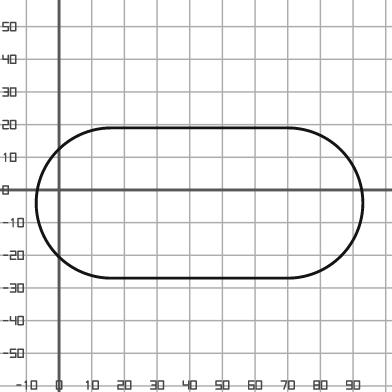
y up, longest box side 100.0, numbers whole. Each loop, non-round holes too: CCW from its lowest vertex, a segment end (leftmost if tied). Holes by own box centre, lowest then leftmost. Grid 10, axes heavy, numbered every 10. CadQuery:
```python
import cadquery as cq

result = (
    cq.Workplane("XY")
    .moveTo(16.0, -27.0)
    .lineTo(70.0, -27.0)
    .threePointArc((93.0, -4.0), (70.0, 19.0))
    .lineTo(16.0, 19.0)
    .threePointArc((-7.0, -4.0), (16.0, -27.0))
    .close()
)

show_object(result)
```